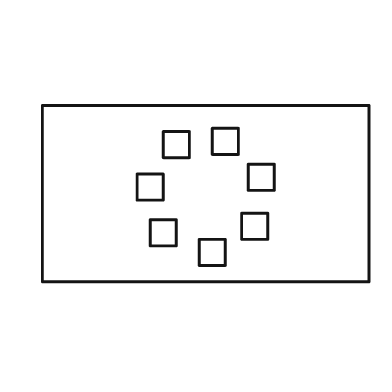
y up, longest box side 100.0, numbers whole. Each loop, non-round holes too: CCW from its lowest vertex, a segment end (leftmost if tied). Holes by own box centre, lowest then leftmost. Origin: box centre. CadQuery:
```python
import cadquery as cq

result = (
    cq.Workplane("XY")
    .moveTo(-50.0, -27.0)
    .lineTo(50.0, -27.0)
    .lineTo(50.0, 27.0)
    .lineTo(-50.0, 27.0)
    .close()
    .moveTo(-2.0, -22.0)
    .lineTo(6.0, -22.0)
    .lineTo(6.0, -14.0)
    .lineTo(-2.0, -14.0)
    .close()
    .moveTo(-17.0, -16.0)
    .lineTo(-9.0, -16.0)
    .lineTo(-9.0, -8.0)
    .lineTo(-17.0, -8.0)
    .close()
    .moveTo(11.0, -14.0)
    .lineTo(19.0, -14.0)
    .lineTo(19.0, -6.0)
    .lineTo(11.0, -6.0)
    .close()
    .moveTo(-21.0, -2.0)
    .lineTo(-13.0, -2.0)
    .lineTo(-13.0, 6.0)
    .lineTo(-21.0, 6.0)
    .close()
    .moveTo(13.0, 1.0)
    .lineTo(21.0, 1.0)
    .lineTo(21.0, 9.0)
    .lineTo(13.0, 9.0)
    .close()
    .moveTo(-13.0, 11.0)
    .lineTo(-5.0, 11.0)
    .lineTo(-5.0, 19.0)
    .lineTo(-13.0, 19.0)
    .close()
    .moveTo(2.0, 12.0)
    .lineTo(10.0, 12.0)
    .lineTo(10.0, 20.0)
    .lineTo(2.0, 20.0)
    .close()
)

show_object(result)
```